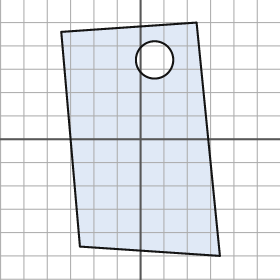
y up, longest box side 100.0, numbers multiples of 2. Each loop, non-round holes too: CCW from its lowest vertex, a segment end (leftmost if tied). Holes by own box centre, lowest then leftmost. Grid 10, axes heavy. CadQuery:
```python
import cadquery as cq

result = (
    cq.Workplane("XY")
    .moveTo(34.0, -50.0)
    .lineTo(24.0, 50.0)
    .lineTo(-34.0, 46.0)
    .lineTo(-26.0, -46.0)
    .close()
    .moveTo(6.0, 34.0)
    .circle(8.0)
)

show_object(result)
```